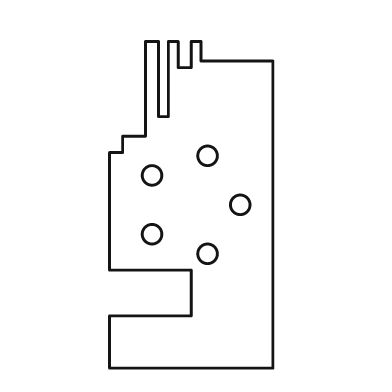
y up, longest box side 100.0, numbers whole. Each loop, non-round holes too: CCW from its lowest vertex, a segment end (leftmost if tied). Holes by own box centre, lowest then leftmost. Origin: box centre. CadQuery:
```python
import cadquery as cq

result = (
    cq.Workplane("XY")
    .moveTo(-25.0, -50.0)
    .lineTo(25.0, -50.0)
    .lineTo(25.0, 44.0)
    .lineTo(3.0, 44.0)
    .lineTo(3.0, 50.0)
    .lineTo(0.0, 50.0)
    .lineTo(0.0, 42.0)
    .lineTo(-4.0, 42.0)
    .lineTo(-4.0, 50.0)
    .lineTo(-7.0, 50.0)
    .lineTo(-7.0, 27.0)
    .lineTo(-10.0, 27.0)
    .lineTo(-10.0, 50.0)
    .lineTo(-14.0, 50.0)
    .lineTo(-14.0, 21.0)
    .lineTo(-21.0, 21.0)
    .lineTo(-21.0, 16.0)
    .lineTo(-25.0, 16.0)
    .lineTo(-25.0, -20.0)
    .lineTo(0.0, -20.0)
    .lineTo(0.0, -34.0)
    .lineTo(-25.0, -34.0)
    .close()
    .moveTo(5.0, -15.0)
    .circle(3.0)
    .moveTo(-12.0, -9.0)
    .circle(3.0)
    .moveTo(15.0, 0.0)
    .circle(3.0)
    .moveTo(-12.0, 9.0)
    .circle(3.0)
    .moveTo(5.0, 15.0)
    .circle(3.0)
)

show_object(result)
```